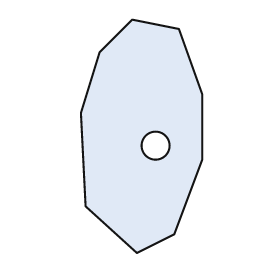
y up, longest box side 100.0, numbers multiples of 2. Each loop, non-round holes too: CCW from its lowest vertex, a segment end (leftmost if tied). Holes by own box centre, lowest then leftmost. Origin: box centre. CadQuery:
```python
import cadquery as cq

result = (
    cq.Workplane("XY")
    .moveTo(-2.0, -50.0)
    .lineTo(14.0, -42.0)
    .lineTo(26.0, -10.0)
    .lineTo(26.0, 18.0)
    .lineTo(16.0, 46.0)
    .lineTo(-4.0, 50.0)
    .lineTo(-18.0, 36.0)
    .lineTo(-26.0, 10.0)
    .lineTo(-24.0, -30.0)
    .close()
    .moveTo(6.0, -4.0)
    .circle(6.0)
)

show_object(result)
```